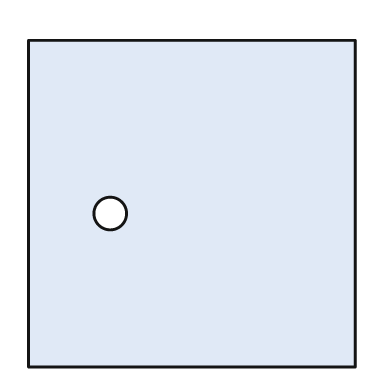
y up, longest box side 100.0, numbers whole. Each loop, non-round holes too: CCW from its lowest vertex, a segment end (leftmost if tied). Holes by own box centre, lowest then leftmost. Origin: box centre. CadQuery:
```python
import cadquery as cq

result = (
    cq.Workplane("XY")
    .moveTo(-50.0, -50.0)
    .lineTo(50.0, -50.0)
    .lineTo(50.0, 50.0)
    .lineTo(-50.0, 50.0)
    .close()
    .moveTo(-25.0, -3.0)
    .circle(5.0)
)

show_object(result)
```